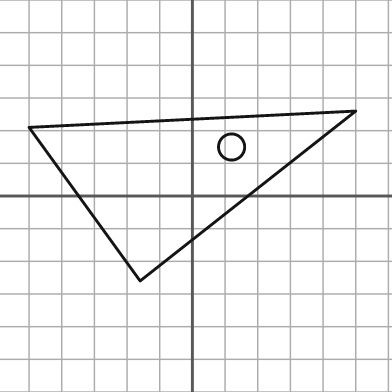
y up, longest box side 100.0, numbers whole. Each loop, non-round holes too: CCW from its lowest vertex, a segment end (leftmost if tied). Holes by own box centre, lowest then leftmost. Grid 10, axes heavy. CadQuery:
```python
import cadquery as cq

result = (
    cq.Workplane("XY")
    .moveTo(-16.0, -26.0)
    .lineTo(50.0, 26.0)
    .lineTo(-50.0, 21.0)
    .close()
    .moveTo(12.0, 15.0)
    .circle(4.0)
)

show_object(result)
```